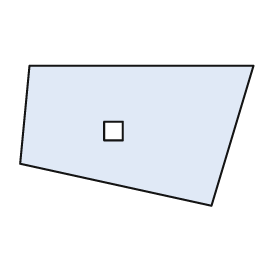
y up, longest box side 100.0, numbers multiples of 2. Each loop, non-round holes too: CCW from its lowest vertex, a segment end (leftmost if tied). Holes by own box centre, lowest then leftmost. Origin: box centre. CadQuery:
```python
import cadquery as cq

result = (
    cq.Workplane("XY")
    .moveTo(32.0, -30.0)
    .lineTo(50.0, 30.0)
    .lineTo(-46.0, 30.0)
    .lineTo(-50.0, -12.0)
    .close()
    .moveTo(-14.0, -2.0)
    .lineTo(-6.0, -2.0)
    .lineTo(-6.0, 6.0)
    .lineTo(-14.0, 6.0)
    .close()
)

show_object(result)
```